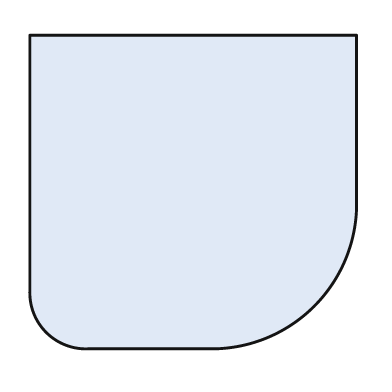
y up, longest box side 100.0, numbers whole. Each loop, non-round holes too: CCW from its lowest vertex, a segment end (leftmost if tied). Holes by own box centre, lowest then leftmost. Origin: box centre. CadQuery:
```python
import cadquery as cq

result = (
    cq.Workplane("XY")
    .moveTo(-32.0, -48.0)
    .lineTo(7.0, -48.0)
    .threePointArc((37.0, -35.0), (50.0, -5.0))
    .lineTo(50.0, 48.0)
    .lineTo(-50.0, 48.0)
    .lineTo(-50.0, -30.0)
    .threePointArc((-45.0, -43.0), (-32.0, -48.0))
    .close()
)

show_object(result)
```